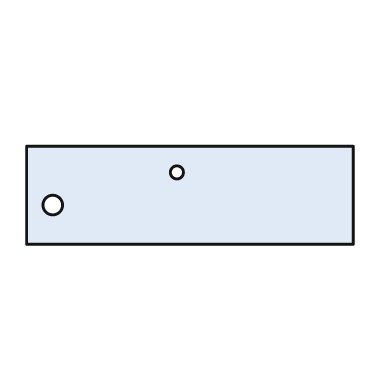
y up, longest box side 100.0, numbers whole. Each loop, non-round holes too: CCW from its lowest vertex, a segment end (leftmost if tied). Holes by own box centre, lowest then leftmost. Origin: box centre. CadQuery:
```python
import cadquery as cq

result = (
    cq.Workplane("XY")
    .moveTo(-50.0, -15.0)
    .lineTo(50.0, -15.0)
    .lineTo(50.0, 15.0)
    .lineTo(-50.0, 15.0)
    .close()
    .moveTo(-42.0, -3.0)
    .circle(3.0)
    .moveTo(-4.0, 7.0)
    .circle(2.0)
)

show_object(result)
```